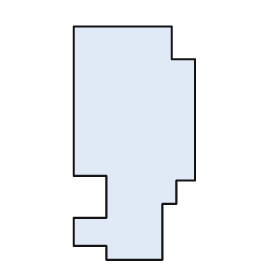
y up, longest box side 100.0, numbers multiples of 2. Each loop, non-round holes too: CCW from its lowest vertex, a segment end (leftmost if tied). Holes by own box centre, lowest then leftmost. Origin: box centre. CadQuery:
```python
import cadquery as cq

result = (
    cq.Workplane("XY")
    .moveTo(-12.0, -50.0)
    .lineTo(12.0, -50.0)
    .lineTo(12.0, -26.0)
    .lineTo(18.0, -26.0)
    .lineTo(18.0, -16.0)
    .lineTo(26.0, -16.0)
    .lineTo(26.0, 36.0)
    .lineTo(16.0, 36.0)
    .lineTo(16.0, 50.0)
    .lineTo(-26.0, 50.0)
    .lineTo(-26.0, -14.0)
    .lineTo(-12.0, -14.0)
    .lineTo(-12.0, -32.0)
    .lineTo(-26.0, -32.0)
    .lineTo(-26.0, -44.0)
    .lineTo(-12.0, -44.0)
    .close()
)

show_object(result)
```